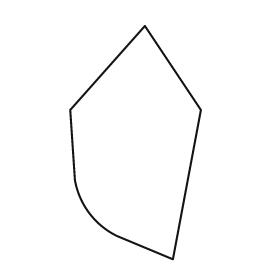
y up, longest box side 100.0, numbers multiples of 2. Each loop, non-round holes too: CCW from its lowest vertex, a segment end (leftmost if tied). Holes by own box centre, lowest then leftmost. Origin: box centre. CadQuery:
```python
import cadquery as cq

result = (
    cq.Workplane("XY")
    .moveTo(16.0, -50.0)
    .lineTo(28.0, 14.0)
    .lineTo(4.0, 50.0)
    .lineTo(-28.0, 14.0)
    .lineTo(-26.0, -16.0)
    .threePointArc((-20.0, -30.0), (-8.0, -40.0))
    .close()
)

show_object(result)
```